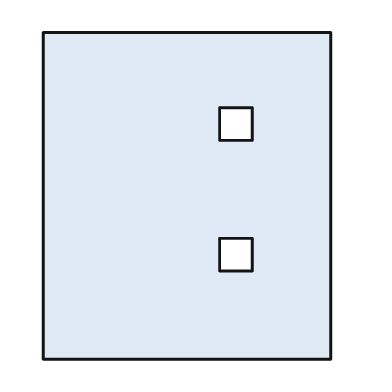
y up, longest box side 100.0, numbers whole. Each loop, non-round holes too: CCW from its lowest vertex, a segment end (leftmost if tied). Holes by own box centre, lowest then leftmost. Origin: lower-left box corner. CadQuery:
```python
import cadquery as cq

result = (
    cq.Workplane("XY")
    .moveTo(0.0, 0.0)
    .lineTo(88.0, 0.0)
    .lineTo(88.0, 100.0)
    .lineTo(0.0, 100.0)
    .close()
    .moveTo(54.0, 27.0)
    .lineTo(64.0, 27.0)
    .lineTo(64.0, 37.0)
    .lineTo(54.0, 37.0)
    .close()
    .moveTo(54.0, 67.0)
    .lineTo(64.0, 67.0)
    .lineTo(64.0, 77.0)
    .lineTo(54.0, 77.0)
    .close()
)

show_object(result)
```